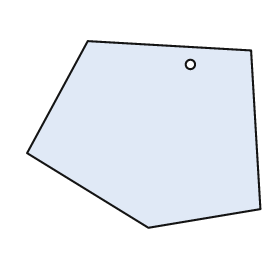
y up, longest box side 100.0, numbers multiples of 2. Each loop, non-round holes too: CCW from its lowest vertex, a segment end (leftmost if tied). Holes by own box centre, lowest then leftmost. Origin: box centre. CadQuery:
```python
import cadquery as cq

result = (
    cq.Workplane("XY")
    .moveTo(2.0, -40.0)
    .lineTo(50.0, -32.0)
    .lineTo(46.0, 36.0)
    .lineTo(-24.0, 40.0)
    .lineTo(-50.0, -8.0)
    .close()
    .moveTo(20.0, 30.0)
    .circle(2.0)
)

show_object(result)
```